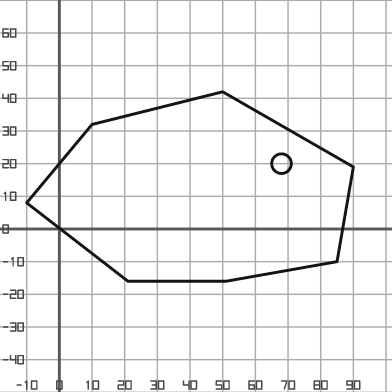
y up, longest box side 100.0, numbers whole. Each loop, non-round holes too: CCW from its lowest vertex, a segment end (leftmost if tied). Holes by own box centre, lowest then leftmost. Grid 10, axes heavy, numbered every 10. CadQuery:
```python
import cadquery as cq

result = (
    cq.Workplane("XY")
    .moveTo(21.0, -16.0)
    .lineTo(51.0, -16.0)
    .lineTo(85.0, -10.0)
    .lineTo(90.0, 19.0)
    .lineTo(50.0, 42.0)
    .lineTo(10.0, 32.0)
    .lineTo(-10.0, 8.0)
    .close()
    .moveTo(68.0, 20.0)
    .circle(3.0)
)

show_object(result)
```